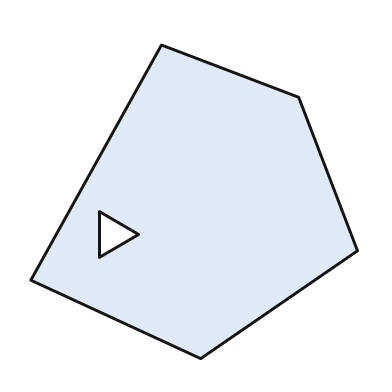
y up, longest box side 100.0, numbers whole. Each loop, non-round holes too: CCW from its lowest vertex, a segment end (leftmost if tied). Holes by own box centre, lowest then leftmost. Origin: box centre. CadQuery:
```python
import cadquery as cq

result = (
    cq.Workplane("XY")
    .moveTo(2.0, -48.0)
    .lineTo(50.0, -15.0)
    .lineTo(32.0, 32.0)
    .lineTo(-10.0, 48.0)
    .lineTo(-50.0, -24.0)
    .close()
    .moveTo(-29.0, -17.0)
    .lineTo(-17.0, -10.0)
    .lineTo(-29.0, -3.0)
    .close()
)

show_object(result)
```